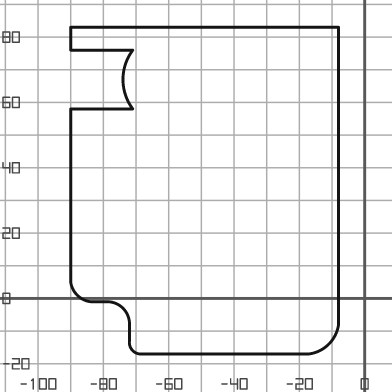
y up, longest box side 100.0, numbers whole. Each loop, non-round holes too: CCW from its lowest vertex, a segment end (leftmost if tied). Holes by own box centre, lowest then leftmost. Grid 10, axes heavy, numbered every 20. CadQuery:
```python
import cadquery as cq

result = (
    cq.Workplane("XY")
    .moveTo(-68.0, -17.0)
    .lineTo(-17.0, -17.0)
    .threePointArc((-11.0, -14.0), (-8.0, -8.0))
    .lineTo(-8.0, 83.0)
    .lineTo(-90.0, 83.0)
    .lineTo(-90.0, 76.0)
    .lineTo(-71.0, 76.0)
    .threePointArc((-74.0, 67.0), (-71.0, 58.0))
    .lineTo(-90.0, 58.0)
    .lineTo(-90.0, 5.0)
    .threePointArc((-88.0, 1.0), (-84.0, -1.0))
    .lineTo(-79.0, -1.0)
    .threePointArc((-74.0, -3.0), (-72.0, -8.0))
    .lineTo(-72.0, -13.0)
    .threePointArc((-71.0, -16.0), (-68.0, -17.0))
    .close()
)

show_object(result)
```